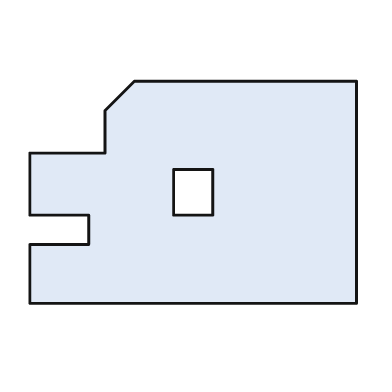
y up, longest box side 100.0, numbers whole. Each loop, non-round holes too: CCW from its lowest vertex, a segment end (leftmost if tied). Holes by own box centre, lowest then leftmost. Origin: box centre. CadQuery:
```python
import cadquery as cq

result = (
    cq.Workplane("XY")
    .moveTo(-50.0, -34.0)
    .lineTo(50.0, -34.0)
    .lineTo(50.0, 34.0)
    .lineTo(-18.0, 34.0)
    .lineTo(-27.0, 25.0)
    .lineTo(-27.0, 12.0)
    .lineTo(-50.0, 12.0)
    .lineTo(-50.0, -7.0)
    .lineTo(-32.0, -7.0)
    .lineTo(-32.0, -16.0)
    .lineTo(-50.0, -16.0)
    .close()
    .moveTo(-6.0, -7.0)
    .lineTo(6.0, -7.0)
    .lineTo(6.0, 7.0)
    .lineTo(-6.0, 7.0)
    .close()
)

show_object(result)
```